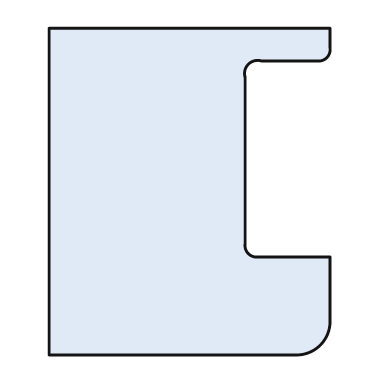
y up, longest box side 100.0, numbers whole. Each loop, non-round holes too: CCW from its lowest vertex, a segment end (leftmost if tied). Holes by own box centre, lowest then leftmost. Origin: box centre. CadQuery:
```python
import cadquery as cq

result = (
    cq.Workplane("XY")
    .moveTo(-43.0, -50.0)
    .lineTo(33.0, -50.0)
    .threePointArc((40.0, -47.0), (43.0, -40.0))
    .lineTo(43.0, -20.0)
    .lineTo(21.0, -20.0)
    .threePointArc((18.0, -19.0), (17.0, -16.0))
    .lineTo(17.0, 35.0)
    .threePointArc((18.0, 39.0), (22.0, 40.0))
    .lineTo(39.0, 40.0)
    .threePointArc((42.0, 41.0), (43.0, 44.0))
    .lineTo(43.0, 50.0)
    .lineTo(-43.0, 50.0)
    .close()
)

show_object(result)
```